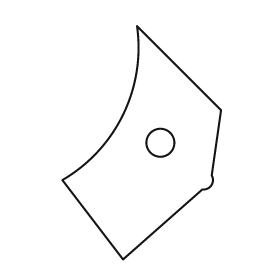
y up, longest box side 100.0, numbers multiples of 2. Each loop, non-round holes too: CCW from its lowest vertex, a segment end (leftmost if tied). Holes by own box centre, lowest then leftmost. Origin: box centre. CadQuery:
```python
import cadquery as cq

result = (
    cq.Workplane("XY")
    .moveTo(-8.0, -50.0)
    .lineTo(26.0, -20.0)
    .threePointArc((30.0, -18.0), (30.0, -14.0))
    .lineTo(34.0, 14.0)
    .lineTo(-2.0, 50.0)
    .threePointArc((-8.0, 12.0), (-34.0, -16.0))
    .close()
    .moveTo(8.0, 0.0)
    .circle(6.0)
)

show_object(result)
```